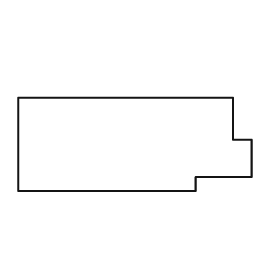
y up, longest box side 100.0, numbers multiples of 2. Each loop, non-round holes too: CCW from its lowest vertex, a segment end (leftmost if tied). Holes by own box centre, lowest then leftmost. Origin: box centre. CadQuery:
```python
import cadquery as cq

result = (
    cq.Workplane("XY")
    .moveTo(-50.0, -20.0)
    .lineTo(26.0, -20.0)
    .lineTo(26.0, -14.0)
    .lineTo(50.0, -14.0)
    .lineTo(50.0, 2.0)
    .lineTo(42.0, 2.0)
    .lineTo(42.0, 20.0)
    .lineTo(-50.0, 20.0)
    .close()
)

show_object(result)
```